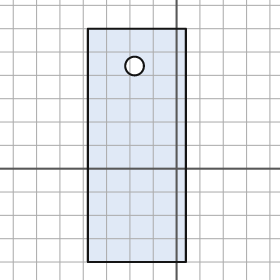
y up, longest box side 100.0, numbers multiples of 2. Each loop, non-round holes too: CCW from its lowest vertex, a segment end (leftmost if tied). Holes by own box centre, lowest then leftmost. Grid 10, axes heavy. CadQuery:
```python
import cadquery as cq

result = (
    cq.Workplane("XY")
    .moveTo(-38.0, -40.0)
    .lineTo(4.0, -40.0)
    .lineTo(4.0, 60.0)
    .lineTo(-38.0, 60.0)
    .close()
    .moveTo(-18.0, 44.0)
    .circle(4.0)
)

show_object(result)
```